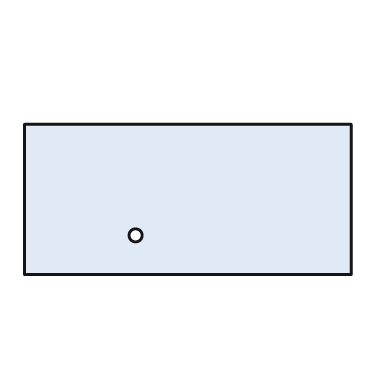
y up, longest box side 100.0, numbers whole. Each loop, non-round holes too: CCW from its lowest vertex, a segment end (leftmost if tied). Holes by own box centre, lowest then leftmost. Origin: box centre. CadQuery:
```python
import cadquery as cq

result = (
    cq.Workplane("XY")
    .moveTo(-50.0, -23.0)
    .lineTo(50.0, -23.0)
    .lineTo(50.0, 23.0)
    .lineTo(-50.0, 23.0)
    .close()
    .moveTo(-16.0, -11.0)
    .circle(2.0)
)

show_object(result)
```